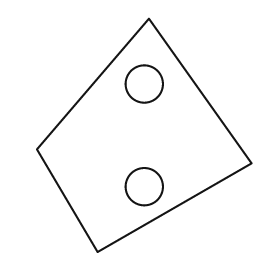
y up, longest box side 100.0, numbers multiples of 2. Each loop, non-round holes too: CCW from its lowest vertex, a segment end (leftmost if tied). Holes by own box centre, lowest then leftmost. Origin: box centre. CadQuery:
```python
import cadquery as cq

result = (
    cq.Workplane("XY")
    .moveTo(-20.0, -50.0)
    .lineTo(46.0, -12.0)
    .lineTo(2.0, 50.0)
    .lineTo(-46.0, -6.0)
    .close()
    .moveTo(0.0, -22.0)
    .circle(8.0)
    .moveTo(0.0, 22.0)
    .circle(8.0)
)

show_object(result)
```